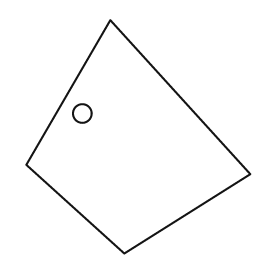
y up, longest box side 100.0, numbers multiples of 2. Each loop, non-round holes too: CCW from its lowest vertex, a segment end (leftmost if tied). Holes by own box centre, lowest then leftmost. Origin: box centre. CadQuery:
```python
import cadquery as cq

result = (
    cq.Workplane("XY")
    .moveTo(-6.0, -50.0)
    .lineTo(48.0, -16.0)
    .lineTo(-12.0, 50.0)
    .lineTo(-48.0, -12.0)
    .close()
    .moveTo(-24.0, 10.0)
    .circle(4.0)
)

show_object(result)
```